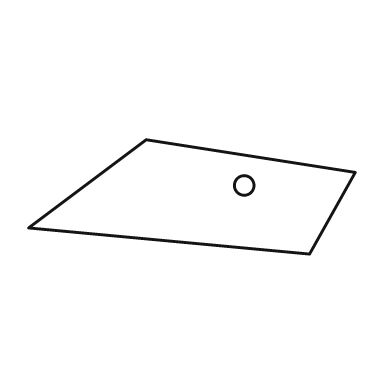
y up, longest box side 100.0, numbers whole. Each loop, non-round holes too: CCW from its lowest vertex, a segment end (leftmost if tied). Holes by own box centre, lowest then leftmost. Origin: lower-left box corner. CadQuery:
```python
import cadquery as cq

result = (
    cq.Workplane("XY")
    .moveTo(86.0, 0.0)
    .lineTo(100.0, 25.0)
    .lineTo(36.0, 35.0)
    .lineTo(0.0, 8.0)
    .close()
    .moveTo(66.0, 21.0)
    .circle(3.0)
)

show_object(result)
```